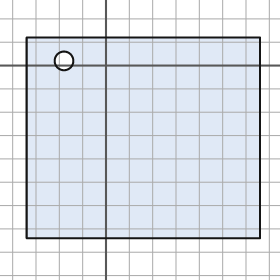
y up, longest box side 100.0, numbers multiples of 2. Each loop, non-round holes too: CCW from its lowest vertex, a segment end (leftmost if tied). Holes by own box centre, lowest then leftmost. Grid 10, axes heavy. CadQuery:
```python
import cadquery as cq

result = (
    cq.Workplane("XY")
    .moveTo(-34.0, -74.0)
    .lineTo(66.0, -74.0)
    .lineTo(66.0, 12.0)
    .lineTo(-34.0, 12.0)
    .close()
    .moveTo(-18.0, 2.0)
    .circle(4.0)
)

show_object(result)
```